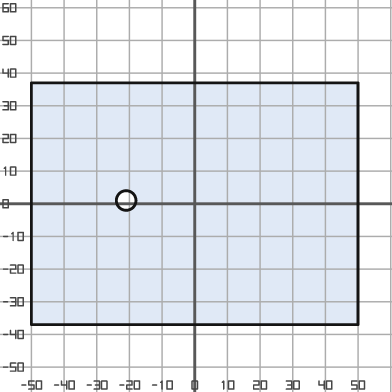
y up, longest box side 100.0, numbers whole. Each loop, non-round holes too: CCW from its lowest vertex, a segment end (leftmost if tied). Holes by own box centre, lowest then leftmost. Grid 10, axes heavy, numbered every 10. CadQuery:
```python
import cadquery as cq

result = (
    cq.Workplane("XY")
    .moveTo(-50.0, -37.0)
    .lineTo(50.0, -37.0)
    .lineTo(50.0, 37.0)
    .lineTo(-50.0, 37.0)
    .close()
    .moveTo(-21.0, 1.0)
    .circle(3.0)
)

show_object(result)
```